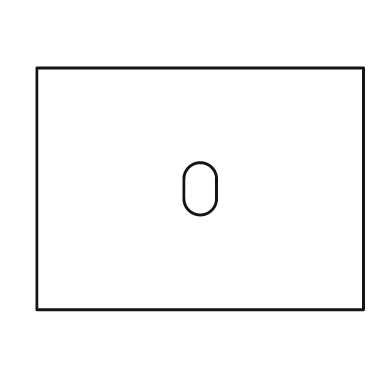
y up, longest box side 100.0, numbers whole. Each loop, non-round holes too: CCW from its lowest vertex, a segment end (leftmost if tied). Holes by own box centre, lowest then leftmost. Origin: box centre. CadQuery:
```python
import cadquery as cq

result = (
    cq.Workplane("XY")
    .moveTo(-50.0, -37.0)
    .lineTo(50.0, -37.0)
    .lineTo(50.0, 37.0)
    .lineTo(-50.0, 37.0)
    .close()
    .moveTo(-5.0, -3.0)
    .threePointArc((0.0, -8.0), (5.0, -3.0))
    .lineTo(5.0, 3.0)
    .threePointArc((0.0, 8.0), (-5.0, 3.0))
    .close()
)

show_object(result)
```